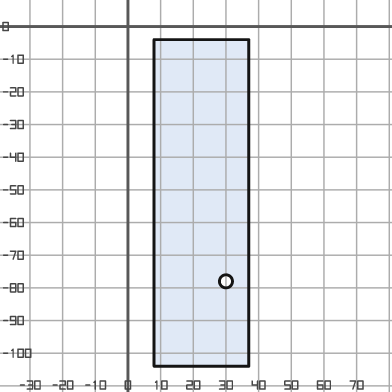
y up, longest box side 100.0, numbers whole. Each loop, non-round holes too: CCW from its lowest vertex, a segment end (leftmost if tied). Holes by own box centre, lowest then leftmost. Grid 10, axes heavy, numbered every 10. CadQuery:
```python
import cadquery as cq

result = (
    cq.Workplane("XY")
    .moveTo(8.0, -104.0)
    .lineTo(37.0, -104.0)
    .lineTo(37.0, -4.0)
    .lineTo(8.0, -4.0)
    .close()
    .moveTo(30.0, -78.0)
    .circle(2.0)
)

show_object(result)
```